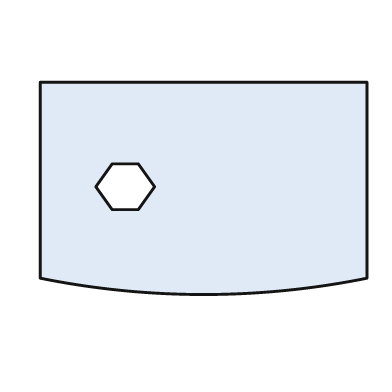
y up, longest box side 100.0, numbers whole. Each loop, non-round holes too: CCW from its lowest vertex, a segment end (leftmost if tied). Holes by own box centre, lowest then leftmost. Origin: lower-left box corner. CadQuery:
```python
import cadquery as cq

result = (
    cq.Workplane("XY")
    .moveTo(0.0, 5.0)
    .threePointArc((50.0, 0.0), (100.0, 5.0))
    .lineTo(100.0, 65.0)
    .lineTo(0.0, 65.0)
    .close()
    .moveTo(22.0, 26.0)
    .lineTo(30.0, 26.0)
    .lineTo(35.0, 33.0)
    .lineTo(30.0, 40.0)
    .lineTo(22.0, 40.0)
    .lineTo(17.0, 33.0)
    .close()
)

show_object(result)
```